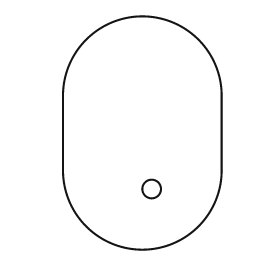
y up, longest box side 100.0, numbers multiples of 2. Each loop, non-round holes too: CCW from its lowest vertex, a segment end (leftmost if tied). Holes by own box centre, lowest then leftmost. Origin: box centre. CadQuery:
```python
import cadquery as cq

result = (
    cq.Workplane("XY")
    .moveTo(-34.0, -16.0)
    .threePointArc((0.0, -50.0), (34.0, -16.0))
    .lineTo(34.0, 16.0)
    .threePointArc((0.0, 50.0), (-34.0, 16.0))
    .close()
    .moveTo(4.0, -24.0)
    .circle(4.0)
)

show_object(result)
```